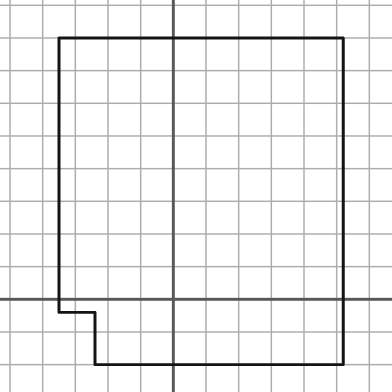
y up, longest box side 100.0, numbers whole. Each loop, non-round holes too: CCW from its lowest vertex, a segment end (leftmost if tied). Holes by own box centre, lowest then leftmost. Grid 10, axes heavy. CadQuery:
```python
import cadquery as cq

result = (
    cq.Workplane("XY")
    .moveTo(-24.0, -20.0)
    .lineTo(52.0, -20.0)
    .lineTo(52.0, 80.0)
    .lineTo(-35.0, 80.0)
    .lineTo(-35.0, -4.0)
    .lineTo(-24.0, -4.0)
    .close()
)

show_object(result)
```